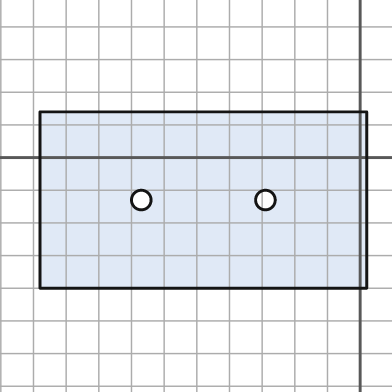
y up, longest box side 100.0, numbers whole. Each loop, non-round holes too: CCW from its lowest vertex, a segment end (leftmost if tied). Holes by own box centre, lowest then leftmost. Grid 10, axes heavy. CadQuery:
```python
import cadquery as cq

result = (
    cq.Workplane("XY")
    .moveTo(-98.0, -40.0)
    .lineTo(2.0, -40.0)
    .lineTo(2.0, 14.0)
    .lineTo(-98.0, 14.0)
    .close()
    .moveTo(-67.0, -13.0)
    .circle(3.0)
    .moveTo(-29.0, -13.0)
    .circle(3.0)
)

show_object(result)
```